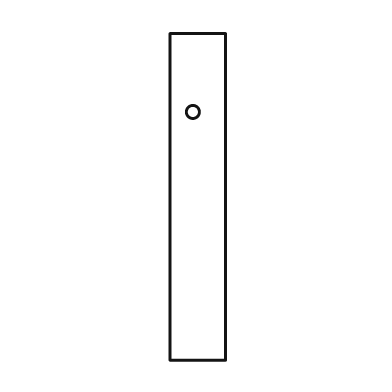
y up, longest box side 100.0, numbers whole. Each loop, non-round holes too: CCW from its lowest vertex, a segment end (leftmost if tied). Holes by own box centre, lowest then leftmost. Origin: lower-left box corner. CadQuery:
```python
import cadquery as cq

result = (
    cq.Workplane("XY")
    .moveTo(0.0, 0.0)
    .lineTo(17.0, 0.0)
    .lineTo(17.0, 100.0)
    .lineTo(0.0, 100.0)
    .close()
    .moveTo(7.0, 76.0)
    .circle(2.0)
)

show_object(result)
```